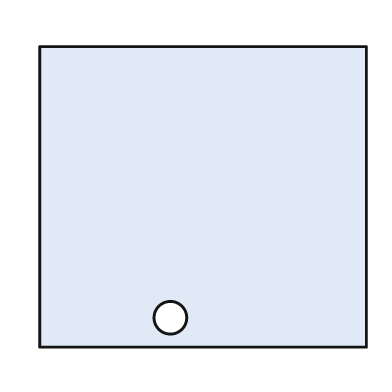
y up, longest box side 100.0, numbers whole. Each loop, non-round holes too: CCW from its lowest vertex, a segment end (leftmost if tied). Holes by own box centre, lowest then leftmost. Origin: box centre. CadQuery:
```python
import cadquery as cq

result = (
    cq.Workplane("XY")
    .moveTo(-50.0, -46.0)
    .lineTo(50.0, -46.0)
    .lineTo(50.0, 46.0)
    .lineTo(-50.0, 46.0)
    .close()
    .moveTo(-10.0, -37.0)
    .circle(5.0)
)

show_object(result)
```